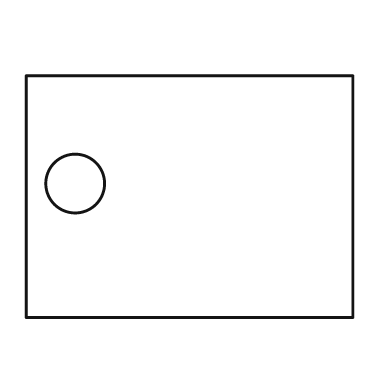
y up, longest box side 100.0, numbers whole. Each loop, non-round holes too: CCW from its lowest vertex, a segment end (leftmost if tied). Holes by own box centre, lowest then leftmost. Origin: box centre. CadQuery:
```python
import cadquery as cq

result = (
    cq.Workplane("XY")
    .moveTo(-50.0, -37.0)
    .lineTo(50.0, -37.0)
    .lineTo(50.0, 37.0)
    .lineTo(-50.0, 37.0)
    .close()
    .moveTo(-35.0, 4.0)
    .circle(9.0)
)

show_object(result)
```